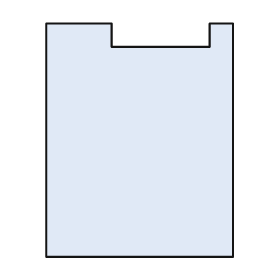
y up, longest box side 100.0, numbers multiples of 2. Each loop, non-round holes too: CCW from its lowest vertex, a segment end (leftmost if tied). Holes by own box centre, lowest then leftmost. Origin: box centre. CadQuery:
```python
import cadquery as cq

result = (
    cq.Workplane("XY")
    .moveTo(-40.0, -50.0)
    .lineTo(40.0, -50.0)
    .lineTo(40.0, 50.0)
    .lineTo(30.0, 50.0)
    .lineTo(30.0, 40.0)
    .lineTo(-12.0, 40.0)
    .lineTo(-12.0, 50.0)
    .lineTo(-40.0, 50.0)
    .close()
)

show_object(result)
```